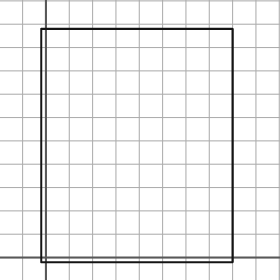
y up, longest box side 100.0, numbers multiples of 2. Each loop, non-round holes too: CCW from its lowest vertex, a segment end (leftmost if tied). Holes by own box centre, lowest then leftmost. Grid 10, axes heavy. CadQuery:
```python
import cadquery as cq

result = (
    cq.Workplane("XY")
    .moveTo(-2.0, -2.0)
    .lineTo(80.0, -2.0)
    .lineTo(80.0, 98.0)
    .lineTo(-2.0, 98.0)
    .close()
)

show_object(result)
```